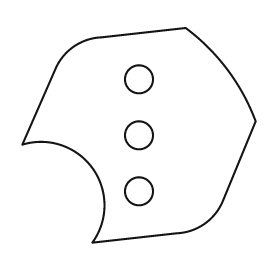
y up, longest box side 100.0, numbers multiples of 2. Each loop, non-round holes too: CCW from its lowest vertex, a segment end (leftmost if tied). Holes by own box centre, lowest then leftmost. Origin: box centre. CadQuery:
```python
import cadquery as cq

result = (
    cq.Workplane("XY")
    .moveTo(-20.0, -46.0)
    .lineTo(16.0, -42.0)
    .threePointArc((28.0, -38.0), (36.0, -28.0))
    .lineTo(50.0, 6.0)
    .threePointArc((38.0, 28.0), (20.0, 46.0))
    .lineTo(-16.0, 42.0)
    .threePointArc((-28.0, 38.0), (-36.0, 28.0))
    .lineTo(-50.0, -4.0)
    .threePointArc((-20.0, -14.0), (-20.0, -46.0))
    .close()
    .moveTo(0.0, -24.0)
    .circle(6.0)
    .moveTo(0.0, 0.0)
    .circle(6.0)
    .moveTo(0.0, 24.0)
    .circle(6.0)
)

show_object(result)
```